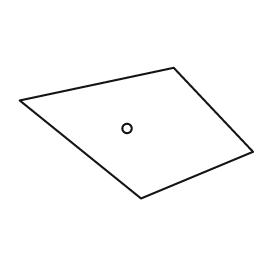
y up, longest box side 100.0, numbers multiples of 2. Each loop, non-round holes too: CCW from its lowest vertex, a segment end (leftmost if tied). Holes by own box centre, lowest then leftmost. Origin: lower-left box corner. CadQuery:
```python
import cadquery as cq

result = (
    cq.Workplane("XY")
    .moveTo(52.0, 0.0)
    .lineTo(100.0, 20.0)
    .lineTo(66.0, 56.0)
    .lineTo(0.0, 42.0)
    .close()
    .moveTo(46.0, 30.0)
    .circle(2.0)
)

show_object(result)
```